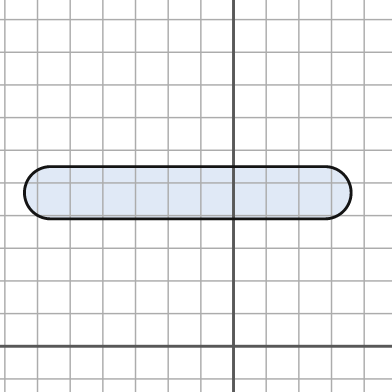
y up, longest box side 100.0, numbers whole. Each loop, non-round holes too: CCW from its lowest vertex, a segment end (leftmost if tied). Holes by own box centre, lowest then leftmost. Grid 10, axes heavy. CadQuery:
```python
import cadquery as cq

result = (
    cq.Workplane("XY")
    .moveTo(-56.0, 39.0)
    .lineTo(28.0, 39.0)
    .threePointArc((36.0, 47.0), (28.0, 55.0))
    .lineTo(-56.0, 55.0)
    .threePointArc((-64.0, 47.0), (-56.0, 39.0))
    .close()
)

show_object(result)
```